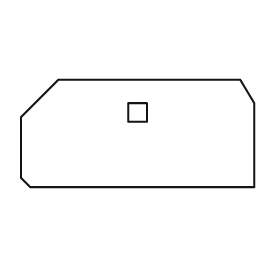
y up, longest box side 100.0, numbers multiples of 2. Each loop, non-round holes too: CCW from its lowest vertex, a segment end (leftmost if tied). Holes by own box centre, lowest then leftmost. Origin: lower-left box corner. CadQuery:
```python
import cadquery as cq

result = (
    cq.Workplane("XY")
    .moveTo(4.0, 0.0)
    .lineTo(100.0, 0.0)
    .lineTo(100.0, 36.0)
    .lineTo(94.0, 46.0)
    .lineTo(16.0, 46.0)
    .lineTo(0.0, 30.0)
    .lineTo(0.0, 4.0)
    .close()
    .moveTo(46.0, 28.0)
    .lineTo(54.0, 28.0)
    .lineTo(54.0, 36.0)
    .lineTo(46.0, 36.0)
    .close()
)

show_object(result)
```